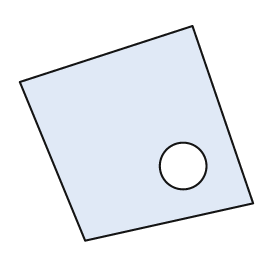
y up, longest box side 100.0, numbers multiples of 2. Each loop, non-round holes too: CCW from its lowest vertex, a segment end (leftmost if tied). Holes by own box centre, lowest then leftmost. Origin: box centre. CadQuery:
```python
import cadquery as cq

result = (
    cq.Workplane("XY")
    .moveTo(-22.0, -46.0)
    .lineTo(50.0, -30.0)
    .lineTo(24.0, 46.0)
    .lineTo(-50.0, 22.0)
    .close()
    .moveTo(20.0, -14.0)
    .circle(10.0)
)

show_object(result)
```